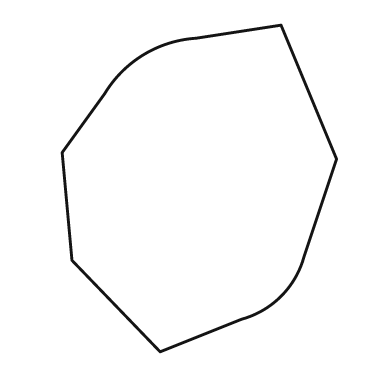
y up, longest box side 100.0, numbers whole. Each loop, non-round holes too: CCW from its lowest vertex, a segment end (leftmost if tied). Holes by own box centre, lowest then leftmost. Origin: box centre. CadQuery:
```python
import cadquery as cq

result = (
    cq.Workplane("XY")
    .moveTo(-12.0, -50.0)
    .lineTo(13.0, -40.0)
    .threePointArc((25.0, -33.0), (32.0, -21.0))
    .lineTo(42.0, 9.0)
    .lineTo(25.0, 50.0)
    .lineTo(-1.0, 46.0)
    .threePointArc((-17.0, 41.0), (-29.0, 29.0))
    .lineTo(-42.0, 11.0)
    .lineTo(-39.0, -22.0)
    .close()
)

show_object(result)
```